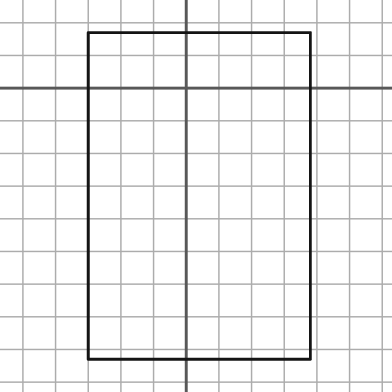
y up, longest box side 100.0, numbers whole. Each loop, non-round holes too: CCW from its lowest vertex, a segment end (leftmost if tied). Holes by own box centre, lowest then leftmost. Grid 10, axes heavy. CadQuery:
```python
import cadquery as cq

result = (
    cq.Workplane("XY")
    .moveTo(-30.0, -83.0)
    .lineTo(38.0, -83.0)
    .lineTo(38.0, 17.0)
    .lineTo(-30.0, 17.0)
    .close()
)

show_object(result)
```